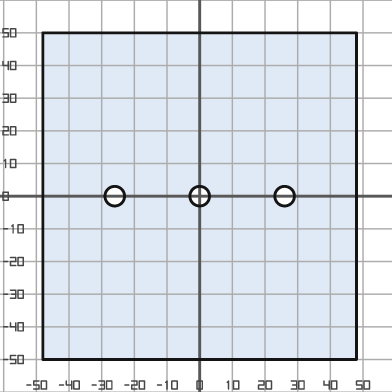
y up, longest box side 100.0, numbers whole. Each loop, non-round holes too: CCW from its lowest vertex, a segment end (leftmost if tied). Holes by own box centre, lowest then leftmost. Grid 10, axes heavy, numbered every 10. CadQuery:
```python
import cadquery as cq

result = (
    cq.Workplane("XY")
    .moveTo(-48.0, -50.0)
    .lineTo(48.0, -50.0)
    .lineTo(48.0, 50.0)
    .lineTo(-48.0, 50.0)
    .close()
    .moveTo(-26.0, 0.0)
    .circle(3.0)
    .moveTo(0.0, 0.0)
    .circle(3.0)
    .moveTo(26.0, 0.0)
    .circle(3.0)
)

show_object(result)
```